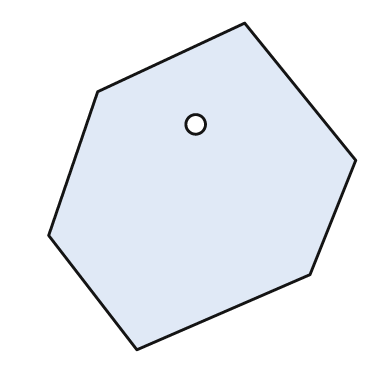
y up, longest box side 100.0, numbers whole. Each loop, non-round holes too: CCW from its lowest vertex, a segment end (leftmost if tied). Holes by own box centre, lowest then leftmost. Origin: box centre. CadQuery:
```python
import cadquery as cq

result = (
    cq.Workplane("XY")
    .moveTo(-20.0, -50.0)
    .lineTo(33.0, -27.0)
    .lineTo(47.0, 8.0)
    .lineTo(13.0, 50.0)
    .lineTo(-32.0, 29.0)
    .lineTo(-47.0, -15.0)
    .close()
    .moveTo(-2.0, 19.0)
    .circle(3.0)
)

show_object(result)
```